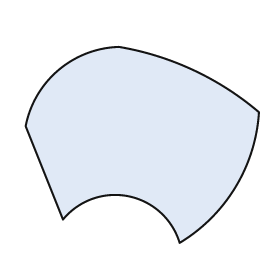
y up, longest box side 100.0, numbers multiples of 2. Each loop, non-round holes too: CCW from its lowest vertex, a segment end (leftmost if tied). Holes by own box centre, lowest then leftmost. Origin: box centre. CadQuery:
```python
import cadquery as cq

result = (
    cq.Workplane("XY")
    .moveTo(16.0, -42.0)
    .threePointArc((40.0, -18.0), (50.0, 14.0))
    .threePointArc((22.0, 32.0), (-10.0, 42.0))
    .threePointArc((-36.0, 32.0), (-50.0, 8.0))
    .lineTo(-34.0, -32.0)
    .threePointArc((-6.0, -22.0), (16.0, -42.0))
    .close()
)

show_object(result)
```